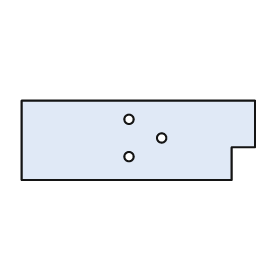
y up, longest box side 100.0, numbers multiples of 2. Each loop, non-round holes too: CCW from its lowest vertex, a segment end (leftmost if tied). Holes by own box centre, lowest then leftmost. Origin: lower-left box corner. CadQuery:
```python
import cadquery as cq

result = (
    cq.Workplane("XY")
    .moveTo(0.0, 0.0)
    .lineTo(90.0, 0.0)
    .lineTo(90.0, 14.0)
    .lineTo(100.0, 14.0)
    .lineTo(100.0, 34.0)
    .lineTo(0.0, 34.0)
    .close()
    .moveTo(46.0, 10.0)
    .circle(2.0)
    .moveTo(60.0, 18.0)
    .circle(2.0)
    .moveTo(46.0, 26.0)
    .circle(2.0)
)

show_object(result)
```